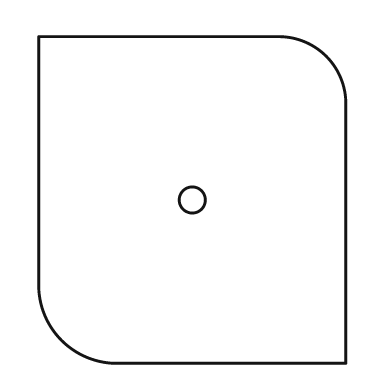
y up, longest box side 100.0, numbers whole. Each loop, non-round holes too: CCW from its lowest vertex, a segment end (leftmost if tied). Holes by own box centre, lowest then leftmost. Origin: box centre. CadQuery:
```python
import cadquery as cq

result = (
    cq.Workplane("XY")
    .moveTo(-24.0, -50.0)
    .lineTo(47.0, -50.0)
    .lineTo(47.0, 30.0)
    .threePointArc((41.0, 44.0), (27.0, 50.0))
    .lineTo(-47.0, 50.0)
    .lineTo(-47.0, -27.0)
    .threePointArc((-40.0, -43.0), (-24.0, -50.0))
    .close()
    .moveTo(0.0, 0.0)
    .circle(4.0)
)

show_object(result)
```